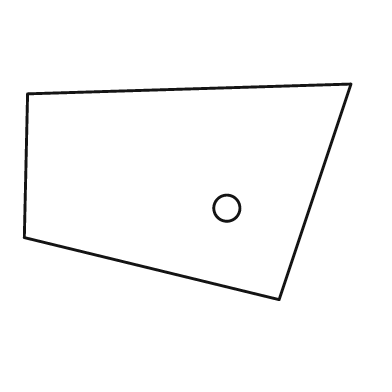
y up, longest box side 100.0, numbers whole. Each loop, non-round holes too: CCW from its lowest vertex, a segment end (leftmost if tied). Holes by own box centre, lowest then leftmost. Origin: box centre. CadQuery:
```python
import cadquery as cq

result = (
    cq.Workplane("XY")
    .moveTo(28.0, -33.0)
    .lineTo(50.0, 33.0)
    .lineTo(-49.0, 30.0)
    .lineTo(-50.0, -14.0)
    .close()
    .moveTo(12.0, -5.0)
    .circle(4.0)
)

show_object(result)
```